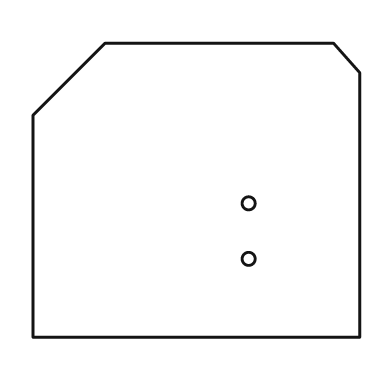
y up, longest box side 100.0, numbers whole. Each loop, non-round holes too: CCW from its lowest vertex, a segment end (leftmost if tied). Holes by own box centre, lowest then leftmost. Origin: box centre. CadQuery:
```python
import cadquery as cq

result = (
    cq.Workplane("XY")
    .moveTo(-50.0, -45.0)
    .lineTo(50.0, -45.0)
    .lineTo(50.0, 36.0)
    .lineTo(42.0, 45.0)
    .lineTo(-28.0, 45.0)
    .lineTo(-50.0, 23.0)
    .close()
    .moveTo(16.0, -21.0)
    .circle(2.0)
    .moveTo(16.0, -4.0)
    .circle(2.0)
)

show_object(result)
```